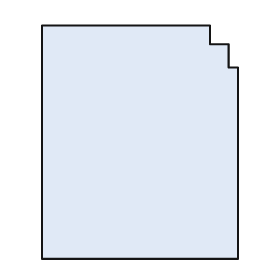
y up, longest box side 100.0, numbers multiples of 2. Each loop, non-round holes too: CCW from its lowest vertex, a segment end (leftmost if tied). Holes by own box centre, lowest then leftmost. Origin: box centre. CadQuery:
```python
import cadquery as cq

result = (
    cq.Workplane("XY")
    .moveTo(-42.0, -50.0)
    .lineTo(42.0, -50.0)
    .lineTo(42.0, 32.0)
    .lineTo(38.0, 32.0)
    .lineTo(38.0, 42.0)
    .lineTo(30.0, 42.0)
    .lineTo(30.0, 50.0)
    .lineTo(-42.0, 50.0)
    .close()
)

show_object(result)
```